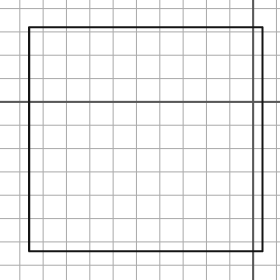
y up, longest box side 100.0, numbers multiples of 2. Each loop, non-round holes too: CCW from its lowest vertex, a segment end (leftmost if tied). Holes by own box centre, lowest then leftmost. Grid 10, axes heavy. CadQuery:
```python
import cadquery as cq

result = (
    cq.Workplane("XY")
    .moveTo(-96.0, -64.0)
    .lineTo(4.0, -64.0)
    .lineTo(4.0, 32.0)
    .lineTo(-96.0, 32.0)
    .close()
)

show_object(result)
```